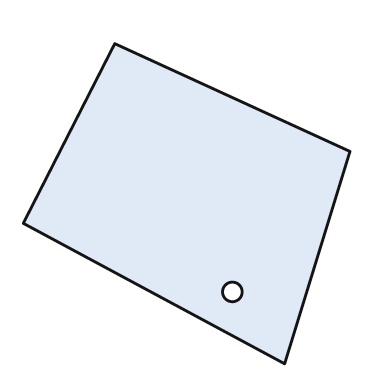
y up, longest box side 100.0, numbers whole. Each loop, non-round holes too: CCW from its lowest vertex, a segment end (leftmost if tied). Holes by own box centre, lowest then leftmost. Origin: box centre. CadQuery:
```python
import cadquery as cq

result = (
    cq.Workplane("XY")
    .moveTo(30.0, -49.0)
    .lineTo(50.0, 16.0)
    .lineTo(-22.0, 49.0)
    .lineTo(-50.0, -6.0)
    .close()
    .moveTo(14.0, -27.0)
    .circle(3.0)
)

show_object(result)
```